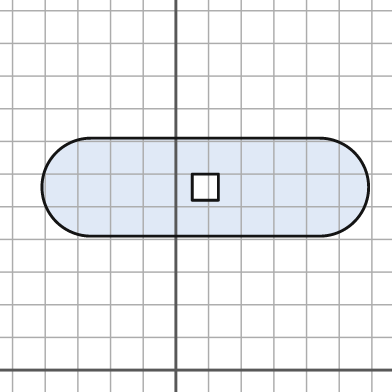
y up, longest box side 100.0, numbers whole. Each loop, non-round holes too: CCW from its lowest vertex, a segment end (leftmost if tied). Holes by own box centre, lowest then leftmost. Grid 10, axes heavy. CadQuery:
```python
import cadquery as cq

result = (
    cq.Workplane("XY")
    .moveTo(-26.0, 41.0)
    .lineTo(44.0, 41.0)
    .threePointArc((59.0, 56.0), (44.0, 71.0))
    .lineTo(-26.0, 71.0)
    .threePointArc((-41.0, 56.0), (-26.0, 41.0))
    .close()
    .moveTo(5.0, 52.0)
    .lineTo(13.0, 52.0)
    .lineTo(13.0, 60.0)
    .lineTo(5.0, 60.0)
    .close()
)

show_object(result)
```